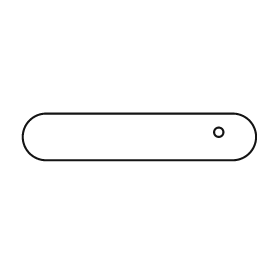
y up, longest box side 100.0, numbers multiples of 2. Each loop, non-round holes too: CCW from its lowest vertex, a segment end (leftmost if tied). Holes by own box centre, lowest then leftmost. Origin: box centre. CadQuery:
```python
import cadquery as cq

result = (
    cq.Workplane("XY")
    .moveTo(-40.0, -10.0)
    .lineTo(40.0, -10.0)
    .threePointArc((50.0, 0.0), (40.0, 10.0))
    .lineTo(-40.0, 10.0)
    .threePointArc((-50.0, 0.0), (-40.0, -10.0))
    .close()
    .moveTo(34.0, 2.0)
    .circle(2.0)
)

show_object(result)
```